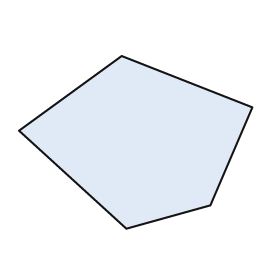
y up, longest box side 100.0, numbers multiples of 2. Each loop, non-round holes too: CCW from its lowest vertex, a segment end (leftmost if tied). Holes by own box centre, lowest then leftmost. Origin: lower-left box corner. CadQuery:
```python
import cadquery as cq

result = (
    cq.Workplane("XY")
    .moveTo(46.0, 0.0)
    .lineTo(82.0, 10.0)
    .lineTo(100.0, 52.0)
    .lineTo(44.0, 74.0)
    .lineTo(0.0, 42.0)
    .close()
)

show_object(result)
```